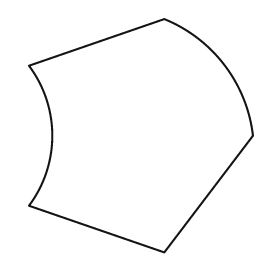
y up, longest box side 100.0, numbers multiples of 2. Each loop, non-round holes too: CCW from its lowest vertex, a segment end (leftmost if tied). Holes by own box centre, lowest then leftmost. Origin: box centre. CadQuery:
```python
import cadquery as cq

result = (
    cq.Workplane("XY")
    .moveTo(10.0, -50.0)
    .lineTo(48.0, 0.0)
    .threePointArc((36.0, 30.0), (10.0, 50.0))
    .lineTo(-48.0, 30.0)
    .threePointArc((-38.0, 0.0), (-48.0, -30.0))
    .close()
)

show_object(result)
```